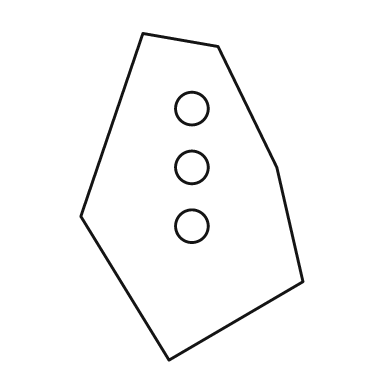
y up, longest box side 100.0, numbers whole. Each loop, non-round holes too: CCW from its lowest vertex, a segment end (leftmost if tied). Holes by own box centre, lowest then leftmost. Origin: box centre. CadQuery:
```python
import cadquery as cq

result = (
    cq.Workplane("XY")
    .moveTo(-7.0, -50.0)
    .lineTo(34.0, -26.0)
    .lineTo(26.0, 9.0)
    .lineTo(8.0, 46.0)
    .lineTo(-15.0, 50.0)
    .lineTo(-34.0, -6.0)
    .close()
    .moveTo(0.0, -9.0)
    .circle(5.0)
    .moveTo(0.0, 9.0)
    .circle(5.0)
    .moveTo(0.0, 27.0)
    .circle(5.0)
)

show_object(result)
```